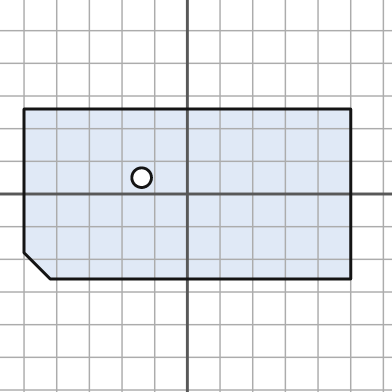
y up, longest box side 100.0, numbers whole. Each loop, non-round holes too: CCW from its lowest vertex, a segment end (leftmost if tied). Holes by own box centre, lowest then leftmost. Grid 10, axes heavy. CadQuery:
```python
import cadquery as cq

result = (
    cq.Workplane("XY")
    .moveTo(-42.0, -26.0)
    .lineTo(50.0, -26.0)
    .lineTo(50.0, 26.0)
    .lineTo(-50.0, 26.0)
    .lineTo(-50.0, -18.0)
    .close()
    .moveTo(-14.0, 5.0)
    .circle(3.0)
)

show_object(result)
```